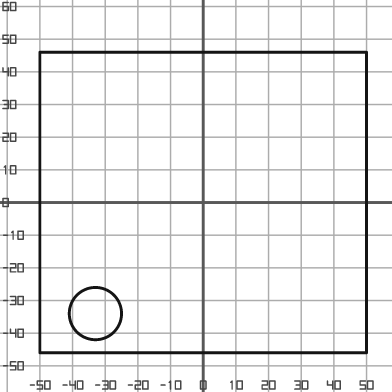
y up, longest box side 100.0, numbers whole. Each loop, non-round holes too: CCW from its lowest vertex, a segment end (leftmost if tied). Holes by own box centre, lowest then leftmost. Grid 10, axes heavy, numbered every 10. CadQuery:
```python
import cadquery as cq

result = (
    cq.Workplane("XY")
    .moveTo(-50.0, -46.0)
    .lineTo(50.0, -46.0)
    .lineTo(50.0, 46.0)
    .lineTo(-50.0, 46.0)
    .close()
    .moveTo(-33.0, -34.0)
    .circle(8.0)
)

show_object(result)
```